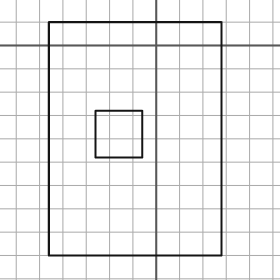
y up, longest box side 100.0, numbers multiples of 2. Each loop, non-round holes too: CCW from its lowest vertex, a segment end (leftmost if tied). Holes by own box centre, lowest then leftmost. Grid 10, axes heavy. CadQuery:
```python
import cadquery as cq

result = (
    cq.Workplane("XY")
    .moveTo(-46.0, -90.0)
    .lineTo(28.0, -90.0)
    .lineTo(28.0, 10.0)
    .lineTo(-46.0, 10.0)
    .close()
    .moveTo(-26.0, -48.0)
    .lineTo(-6.0, -48.0)
    .lineTo(-6.0, -28.0)
    .lineTo(-26.0, -28.0)
    .close()
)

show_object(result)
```